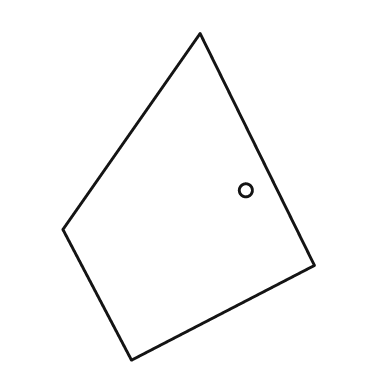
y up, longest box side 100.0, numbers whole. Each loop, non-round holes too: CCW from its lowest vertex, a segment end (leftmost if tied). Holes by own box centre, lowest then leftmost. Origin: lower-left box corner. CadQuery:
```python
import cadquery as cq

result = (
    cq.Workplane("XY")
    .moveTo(21.0, 0.0)
    .lineTo(77.0, 29.0)
    .lineTo(42.0, 100.0)
    .lineTo(0.0, 40.0)
    .close()
    .moveTo(56.0, 52.0)
    .circle(2.0)
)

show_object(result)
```